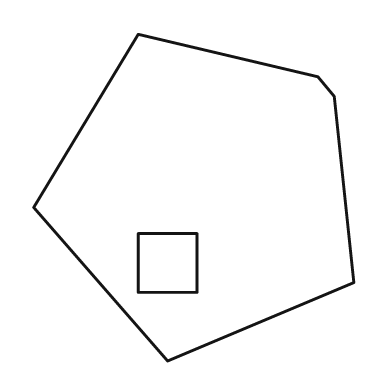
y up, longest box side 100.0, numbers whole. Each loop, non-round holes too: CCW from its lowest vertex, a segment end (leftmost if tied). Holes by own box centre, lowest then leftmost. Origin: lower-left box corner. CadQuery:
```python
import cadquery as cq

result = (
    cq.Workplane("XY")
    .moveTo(41.0, 0.0)
    .lineTo(98.0, 24.0)
    .lineTo(92.0, 81.0)
    .lineTo(87.0, 87.0)
    .lineTo(32.0, 100.0)
    .lineTo(0.0, 47.0)
    .close()
    .moveTo(32.0, 21.0)
    .lineTo(50.0, 21.0)
    .lineTo(50.0, 39.0)
    .lineTo(32.0, 39.0)
    .close()
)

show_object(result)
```